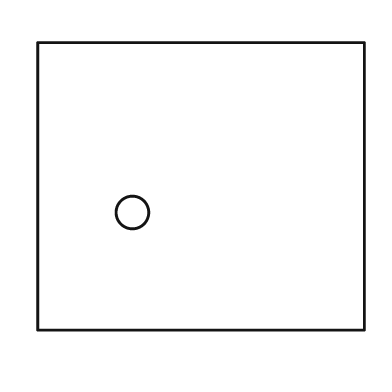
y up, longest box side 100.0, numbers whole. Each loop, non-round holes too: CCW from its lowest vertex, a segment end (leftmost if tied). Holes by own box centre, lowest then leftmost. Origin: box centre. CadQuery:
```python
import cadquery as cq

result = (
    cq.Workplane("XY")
    .moveTo(-50.0, -44.0)
    .lineTo(50.0, -44.0)
    .lineTo(50.0, 44.0)
    .lineTo(-50.0, 44.0)
    .close()
    .moveTo(-21.0, -8.0)
    .circle(5.0)
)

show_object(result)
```